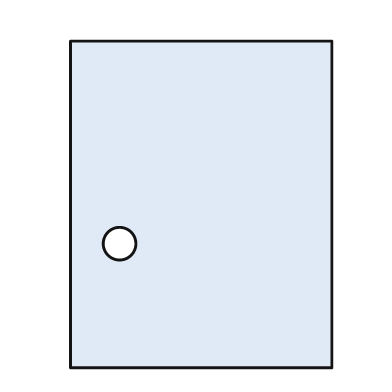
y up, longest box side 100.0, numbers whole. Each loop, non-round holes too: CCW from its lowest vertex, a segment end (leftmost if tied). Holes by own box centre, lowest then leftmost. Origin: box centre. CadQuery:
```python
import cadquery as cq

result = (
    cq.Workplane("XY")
    .moveTo(-40.0, -50.0)
    .lineTo(40.0, -50.0)
    .lineTo(40.0, 50.0)
    .lineTo(-40.0, 50.0)
    .close()
    .moveTo(-25.0, -12.0)
    .circle(5.0)
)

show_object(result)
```